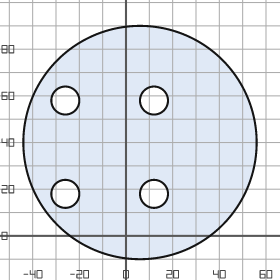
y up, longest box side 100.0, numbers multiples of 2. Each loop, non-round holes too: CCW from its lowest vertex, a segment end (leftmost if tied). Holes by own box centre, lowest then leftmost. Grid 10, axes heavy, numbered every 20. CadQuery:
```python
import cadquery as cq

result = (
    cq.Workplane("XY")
    .moveTo(6.0, 40.0)
    .circle(50.0)
    .moveTo(-26.0, 18.0)
    .circle(6.0)
    .moveTo(12.0, 18.0)
    .circle(6.0)
    .moveTo(-26.0, 58.0)
    .circle(6.0)
    .moveTo(12.0, 58.0)
    .circle(6.0)
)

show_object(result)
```